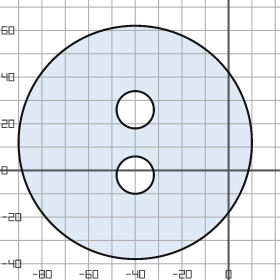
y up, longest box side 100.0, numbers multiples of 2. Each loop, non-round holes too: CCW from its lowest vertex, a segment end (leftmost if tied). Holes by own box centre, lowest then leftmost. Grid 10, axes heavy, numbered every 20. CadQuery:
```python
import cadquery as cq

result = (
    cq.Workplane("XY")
    .moveTo(-40.0, 12.0)
    .circle(50.0)
    .moveTo(-40.0, -2.0)
    .circle(8.0)
    .moveTo(-40.0, 26.0)
    .circle(8.0)
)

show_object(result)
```